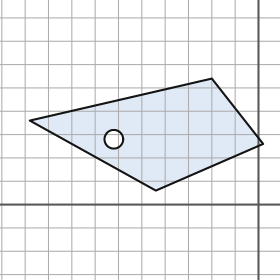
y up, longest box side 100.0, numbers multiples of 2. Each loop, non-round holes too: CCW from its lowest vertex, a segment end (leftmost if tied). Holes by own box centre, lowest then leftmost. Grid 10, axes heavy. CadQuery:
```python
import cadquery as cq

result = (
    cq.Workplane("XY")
    .moveTo(-44.0, 6.0)
    .lineTo(2.0, 26.0)
    .lineTo(-20.0, 54.0)
    .lineTo(-98.0, 36.0)
    .close()
    .moveTo(-62.0, 28.0)
    .circle(4.0)
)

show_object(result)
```